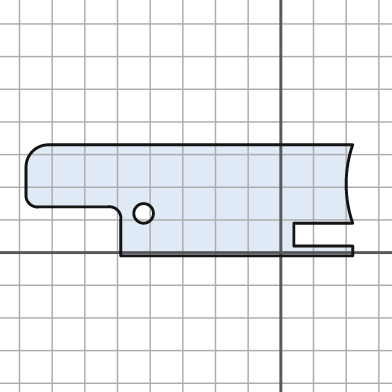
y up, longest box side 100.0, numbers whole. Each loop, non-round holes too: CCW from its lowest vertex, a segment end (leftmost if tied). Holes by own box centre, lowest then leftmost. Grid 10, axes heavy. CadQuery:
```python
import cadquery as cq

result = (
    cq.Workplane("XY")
    .moveTo(-49.0, -1.0)
    .lineTo(22.0, -1.0)
    .lineTo(22.0, 2.0)
    .lineTo(4.0, 2.0)
    .lineTo(4.0, 9.0)
    .lineTo(22.0, 9.0)
    .threePointArc((20.0, 21.0), (22.0, 33.0))
    .lineTo(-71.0, 33.0)
    .threePointArc((-76.0, 31.0), (-78.0, 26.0))
    .lineTo(-78.0, 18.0)
    .threePointArc((-77.0, 15.0), (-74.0, 14.0))
    .lineTo(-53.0, 14.0)
    .threePointArc((-50.0, 13.0), (-49.0, 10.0))
    .close()
    .moveTo(-42.0, 12.0)
    .circle(3.0)
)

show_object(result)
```